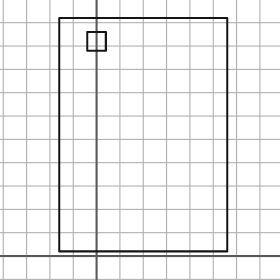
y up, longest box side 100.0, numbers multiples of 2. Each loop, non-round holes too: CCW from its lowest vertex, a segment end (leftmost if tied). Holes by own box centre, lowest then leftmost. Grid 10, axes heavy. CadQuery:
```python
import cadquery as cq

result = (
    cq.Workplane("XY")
    .moveTo(-16.0, 2.0)
    .lineTo(56.0, 2.0)
    .lineTo(56.0, 102.0)
    .lineTo(-16.0, 102.0)
    .close()
    .moveTo(-4.0, 88.0)
    .lineTo(4.0, 88.0)
    .lineTo(4.0, 96.0)
    .lineTo(-4.0, 96.0)
    .close()
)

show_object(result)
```